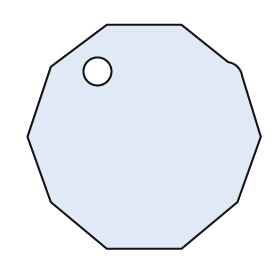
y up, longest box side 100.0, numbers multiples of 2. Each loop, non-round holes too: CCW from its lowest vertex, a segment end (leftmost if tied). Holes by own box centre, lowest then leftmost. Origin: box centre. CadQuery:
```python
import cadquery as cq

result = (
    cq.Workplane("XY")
    .moveTo(-16.0, -48.0)
    .lineTo(16.0, -48.0)
    .lineTo(40.0, -28.0)
    .lineTo(50.0, 0.0)
    .lineTo(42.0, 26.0)
    .threePointArc((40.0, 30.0), (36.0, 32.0))
    .lineTo(16.0, 48.0)
    .lineTo(-16.0, 48.0)
    .lineTo(-40.0, 30.0)
    .lineTo(-50.0, 0.0)
    .lineTo(-40.0, -28.0)
    .close()
    .moveTo(-20.0, 28.0)
    .circle(6.0)
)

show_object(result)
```